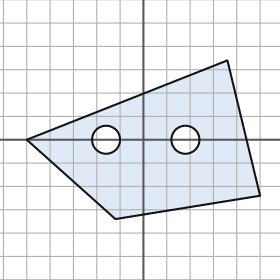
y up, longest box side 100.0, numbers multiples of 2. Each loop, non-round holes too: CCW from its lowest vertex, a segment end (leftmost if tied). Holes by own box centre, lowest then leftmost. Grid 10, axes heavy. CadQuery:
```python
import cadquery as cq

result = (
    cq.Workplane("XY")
    .moveTo(-12.0, -34.0)
    .lineTo(50.0, -24.0)
    .lineTo(36.0, 34.0)
    .lineTo(-50.0, 0.0)
    .close()
    .moveTo(-16.0, 0.0)
    .circle(6.0)
    .moveTo(18.0, 0.0)
    .circle(6.0)
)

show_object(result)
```